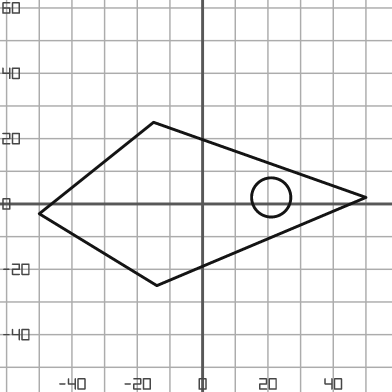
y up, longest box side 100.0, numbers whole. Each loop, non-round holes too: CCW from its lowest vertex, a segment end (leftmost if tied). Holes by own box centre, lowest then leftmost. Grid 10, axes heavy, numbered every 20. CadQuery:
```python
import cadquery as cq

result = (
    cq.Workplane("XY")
    .moveTo(-14.0, -25.0)
    .lineTo(50.0, 2.0)
    .lineTo(-15.0, 25.0)
    .lineTo(-50.0, -3.0)
    .close()
    .moveTo(21.0, 2.0)
    .circle(6.0)
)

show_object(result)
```